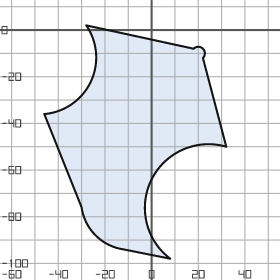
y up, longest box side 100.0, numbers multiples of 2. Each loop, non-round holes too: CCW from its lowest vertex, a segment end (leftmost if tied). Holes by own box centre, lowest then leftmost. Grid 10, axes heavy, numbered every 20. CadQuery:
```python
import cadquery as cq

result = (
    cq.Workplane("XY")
    .moveTo(8.0, -98.0)
    .threePointArc((0.0, -64.0), (32.0, -50.0))
    .lineTo(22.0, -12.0)
    .threePointArc((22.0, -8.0), (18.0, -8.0))
    .lineTo(-28.0, 2.0)
    .threePointArc((-26.0, -22.0), (-46.0, -36.0))
    .lineTo(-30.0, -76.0)
    .threePointArc((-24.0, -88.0), (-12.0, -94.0))
    .close()
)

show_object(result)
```